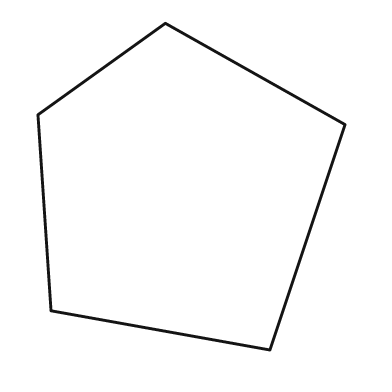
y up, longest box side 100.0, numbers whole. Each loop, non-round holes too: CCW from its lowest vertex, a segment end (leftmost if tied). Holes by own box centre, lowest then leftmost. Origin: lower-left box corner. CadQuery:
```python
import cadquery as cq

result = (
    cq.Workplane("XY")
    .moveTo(71.0, 0.0)
    .lineTo(94.0, 69.0)
    .lineTo(39.0, 100.0)
    .lineTo(0.0, 72.0)
    .lineTo(4.0, 12.0)
    .close()
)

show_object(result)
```